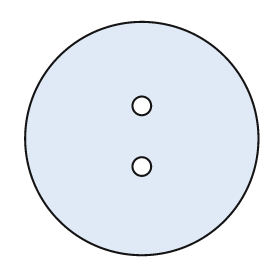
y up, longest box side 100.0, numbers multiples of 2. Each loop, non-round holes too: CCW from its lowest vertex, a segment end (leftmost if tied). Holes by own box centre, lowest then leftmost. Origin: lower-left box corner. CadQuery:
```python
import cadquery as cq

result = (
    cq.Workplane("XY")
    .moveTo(50.0, 50.0)
    .circle(50.0)
    .moveTo(50.0, 38.0)
    .circle(4.0)
    .moveTo(50.0, 64.0)
    .circle(4.0)
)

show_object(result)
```